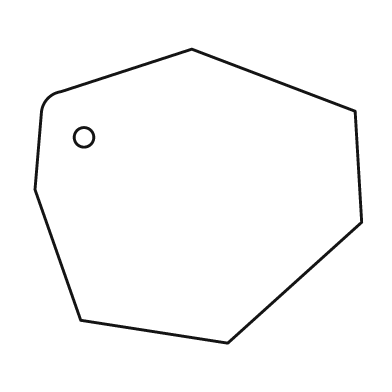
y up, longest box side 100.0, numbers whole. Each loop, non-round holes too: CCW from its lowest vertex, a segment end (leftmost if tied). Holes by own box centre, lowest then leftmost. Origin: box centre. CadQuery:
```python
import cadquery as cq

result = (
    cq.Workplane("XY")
    .moveTo(9.0, -45.0)
    .lineTo(50.0, -8.0)
    .lineTo(48.0, 26.0)
    .lineTo(-2.0, 45.0)
    .lineTo(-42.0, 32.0)
    .threePointArc((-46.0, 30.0), (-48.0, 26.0))
    .lineTo(-50.0, 2.0)
    .lineTo(-36.0, -38.0)
    .close()
    .moveTo(-35.0, 18.0)
    .circle(3.0)
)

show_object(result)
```